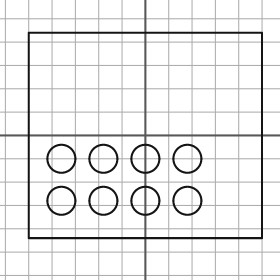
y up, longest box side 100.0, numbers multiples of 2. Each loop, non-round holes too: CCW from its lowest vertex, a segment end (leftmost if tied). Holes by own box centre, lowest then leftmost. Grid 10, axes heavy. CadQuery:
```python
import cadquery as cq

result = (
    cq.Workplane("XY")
    .moveTo(-50.0, -44.0)
    .lineTo(50.0, -44.0)
    .lineTo(50.0, 44.0)
    .lineTo(-50.0, 44.0)
    .close()
    .moveTo(-36.0, -28.0)
    .circle(6.0)
    .moveTo(-18.0, -28.0)
    .circle(6.0)
    .moveTo(0.0, -28.0)
    .circle(6.0)
    .moveTo(18.0, -28.0)
    .circle(6.0)
    .moveTo(-36.0, -10.0)
    .circle(6.0)
    .moveTo(-18.0, -10.0)
    .circle(6.0)
    .moveTo(0.0, -10.0)
    .circle(6.0)
    .moveTo(18.0, -10.0)
    .circle(6.0)
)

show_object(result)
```